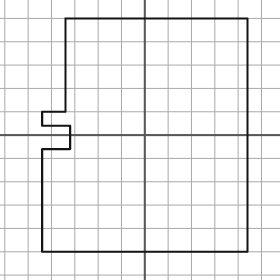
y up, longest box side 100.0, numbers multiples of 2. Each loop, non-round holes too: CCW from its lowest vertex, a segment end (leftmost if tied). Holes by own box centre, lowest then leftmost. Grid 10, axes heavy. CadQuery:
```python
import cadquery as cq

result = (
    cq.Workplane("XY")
    .moveTo(-44.0, -50.0)
    .lineTo(44.0, -50.0)
    .lineTo(44.0, 50.0)
    .lineTo(-34.0, 50.0)
    .lineTo(-34.0, 10.0)
    .lineTo(-44.0, 10.0)
    .lineTo(-44.0, 4.0)
    .lineTo(-32.0, 4.0)
    .lineTo(-32.0, -6.0)
    .lineTo(-44.0, -6.0)
    .close()
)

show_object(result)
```